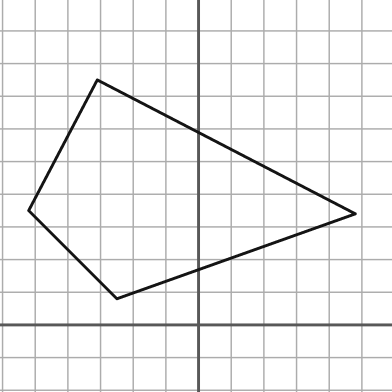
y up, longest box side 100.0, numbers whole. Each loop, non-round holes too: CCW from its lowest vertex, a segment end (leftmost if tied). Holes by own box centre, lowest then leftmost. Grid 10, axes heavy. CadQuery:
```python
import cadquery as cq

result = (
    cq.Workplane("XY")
    .moveTo(-25.0, 8.0)
    .lineTo(48.0, 34.0)
    .lineTo(-31.0, 75.0)
    .lineTo(-52.0, 35.0)
    .close()
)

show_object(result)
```